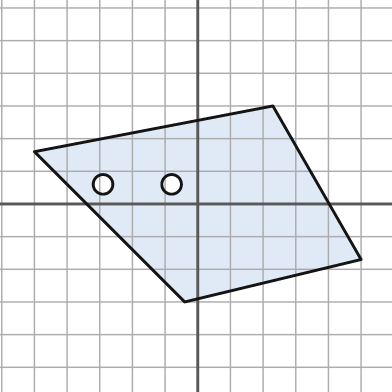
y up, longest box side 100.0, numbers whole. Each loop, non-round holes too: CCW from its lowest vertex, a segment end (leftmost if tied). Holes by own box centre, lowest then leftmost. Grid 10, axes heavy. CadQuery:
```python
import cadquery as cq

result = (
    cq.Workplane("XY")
    .moveTo(-4.0, -30.0)
    .lineTo(50.0, -17.0)
    .lineTo(23.0, 30.0)
    .lineTo(-50.0, 16.0)
    .close()
    .moveTo(-29.0, 6.0)
    .circle(3.0)
    .moveTo(-8.0, 6.0)
    .circle(3.0)
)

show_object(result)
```